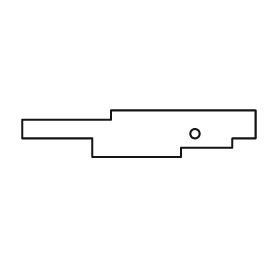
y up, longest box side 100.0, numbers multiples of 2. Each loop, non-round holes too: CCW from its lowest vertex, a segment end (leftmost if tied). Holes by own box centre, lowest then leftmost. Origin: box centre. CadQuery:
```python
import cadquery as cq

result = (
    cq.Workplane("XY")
    .moveTo(-20.0, -10.0)
    .lineTo(18.0, -10.0)
    .lineTo(18.0, -6.0)
    .lineTo(40.0, -6.0)
    .lineTo(40.0, -2.0)
    .lineTo(50.0, -2.0)
    .lineTo(50.0, 10.0)
    .lineTo(-12.0, 10.0)
    .lineTo(-12.0, 6.0)
    .lineTo(-50.0, 6.0)
    .lineTo(-50.0, -2.0)
    .lineTo(-20.0, -2.0)
    .close()
    .moveTo(24.0, 0.0)
    .circle(2.0)
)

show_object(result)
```